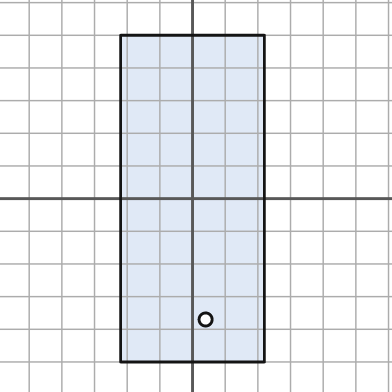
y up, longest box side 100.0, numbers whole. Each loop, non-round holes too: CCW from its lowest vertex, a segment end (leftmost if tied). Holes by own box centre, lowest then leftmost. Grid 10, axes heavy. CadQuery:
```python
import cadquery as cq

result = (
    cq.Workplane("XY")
    .moveTo(-22.0, -50.0)
    .lineTo(22.0, -50.0)
    .lineTo(22.0, 50.0)
    .lineTo(-22.0, 50.0)
    .close()
    .moveTo(4.0, -37.0)
    .circle(2.0)
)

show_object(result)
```